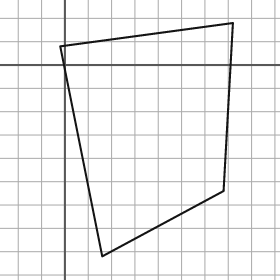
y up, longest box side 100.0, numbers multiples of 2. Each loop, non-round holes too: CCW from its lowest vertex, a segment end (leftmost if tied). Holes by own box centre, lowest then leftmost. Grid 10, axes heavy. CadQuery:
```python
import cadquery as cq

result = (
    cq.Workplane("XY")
    .moveTo(16.0, -82.0)
    .lineTo(68.0, -54.0)
    .lineTo(72.0, 18.0)
    .lineTo(-2.0, 8.0)
    .close()
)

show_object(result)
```